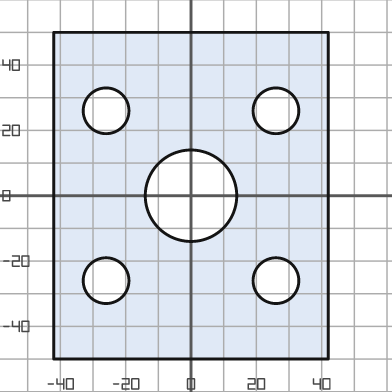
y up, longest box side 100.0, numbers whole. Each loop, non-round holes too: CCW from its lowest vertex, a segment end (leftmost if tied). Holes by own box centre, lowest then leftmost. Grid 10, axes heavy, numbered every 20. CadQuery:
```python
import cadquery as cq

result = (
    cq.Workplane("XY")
    .moveTo(-42.0, -50.0)
    .lineTo(42.0, -50.0)
    .lineTo(42.0, 50.0)
    .lineTo(-42.0, 50.0)
    .close()
    .moveTo(-26.0, -26.0)
    .circle(7.0)
    .moveTo(26.0, -26.0)
    .circle(7.0)
    .moveTo(0.0, 0.0)
    .circle(14.0)
    .moveTo(-26.0, 26.0)
    .circle(7.0)
    .moveTo(26.0, 26.0)
    .circle(7.0)
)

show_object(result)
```